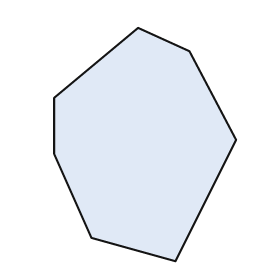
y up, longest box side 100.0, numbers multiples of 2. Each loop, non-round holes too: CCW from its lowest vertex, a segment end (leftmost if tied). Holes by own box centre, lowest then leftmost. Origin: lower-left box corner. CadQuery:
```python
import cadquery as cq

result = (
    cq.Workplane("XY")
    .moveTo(52.0, 0.0)
    .lineTo(78.0, 52.0)
    .lineTo(58.0, 90.0)
    .lineTo(36.0, 100.0)
    .lineTo(0.0, 70.0)
    .lineTo(0.0, 46.0)
    .lineTo(16.0, 10.0)
    .close()
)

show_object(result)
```